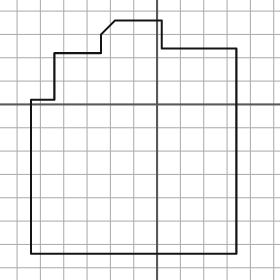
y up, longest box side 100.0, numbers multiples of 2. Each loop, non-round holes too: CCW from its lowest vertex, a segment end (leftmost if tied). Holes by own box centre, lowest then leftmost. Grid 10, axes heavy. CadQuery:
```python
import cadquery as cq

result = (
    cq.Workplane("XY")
    .moveTo(-54.0, -64.0)
    .lineTo(34.0, -64.0)
    .lineTo(34.0, 24.0)
    .lineTo(2.0, 24.0)
    .lineTo(2.0, 36.0)
    .lineTo(-18.0, 36.0)
    .lineTo(-24.0, 30.0)
    .lineTo(-24.0, 22.0)
    .lineTo(-44.0, 22.0)
    .lineTo(-44.0, 2.0)
    .lineTo(-54.0, 2.0)
    .close()
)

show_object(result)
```